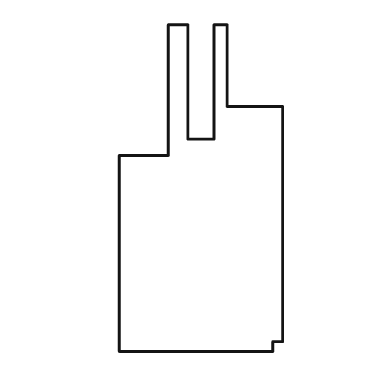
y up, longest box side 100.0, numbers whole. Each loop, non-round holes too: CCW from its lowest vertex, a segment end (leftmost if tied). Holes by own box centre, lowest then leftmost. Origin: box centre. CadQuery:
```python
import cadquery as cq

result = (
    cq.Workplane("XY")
    .moveTo(-25.0, -50.0)
    .lineTo(22.0, -50.0)
    .lineTo(22.0, -47.0)
    .lineTo(25.0, -47.0)
    .lineTo(25.0, 25.0)
    .lineTo(8.0, 25.0)
    .lineTo(8.0, 50.0)
    .lineTo(4.0, 50.0)
    .lineTo(4.0, 15.0)
    .lineTo(-4.0, 15.0)
    .lineTo(-4.0, 50.0)
    .lineTo(-10.0, 50.0)
    .lineTo(-10.0, 10.0)
    .lineTo(-25.0, 10.0)
    .close()
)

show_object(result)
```